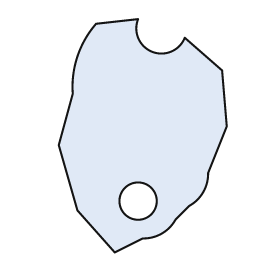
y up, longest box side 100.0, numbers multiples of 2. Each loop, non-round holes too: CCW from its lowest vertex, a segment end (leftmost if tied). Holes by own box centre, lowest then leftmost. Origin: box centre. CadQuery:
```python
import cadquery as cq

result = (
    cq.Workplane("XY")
    .moveTo(-12.0, -50.0)
    .lineTo(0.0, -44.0)
    .threePointArc((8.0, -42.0), (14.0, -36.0))
    .lineTo(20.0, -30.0)
    .threePointArc((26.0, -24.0), (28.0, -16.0))
    .lineTo(36.0, 4.0)
    .lineTo(34.0, 28.0)
    .lineTo(18.0, 42.0)
    .threePointArc((4.0, 36.0), (-2.0, 50.0))
    .lineTo(-20.0, 48.0)
    .threePointArc((-28.0, 34.0), (-30.0, 18.0))
    .lineTo(-36.0, -4.0)
    .lineTo(-28.0, -32.0)
    .close()
    .moveTo(-2.0, -28.0)
    .circle(8.0)
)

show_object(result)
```